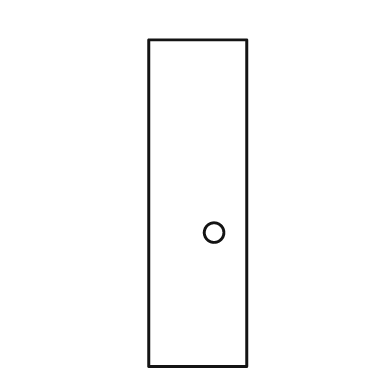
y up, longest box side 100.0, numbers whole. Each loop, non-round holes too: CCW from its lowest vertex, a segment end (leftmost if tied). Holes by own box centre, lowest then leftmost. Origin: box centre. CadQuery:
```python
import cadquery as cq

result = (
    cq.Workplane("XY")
    .moveTo(-15.0, -50.0)
    .lineTo(15.0, -50.0)
    .lineTo(15.0, 50.0)
    .lineTo(-15.0, 50.0)
    .close()
    .moveTo(5.0, -9.0)
    .circle(3.0)
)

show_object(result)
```